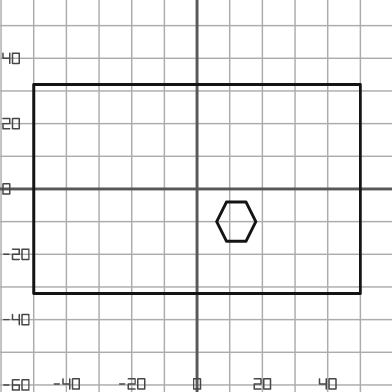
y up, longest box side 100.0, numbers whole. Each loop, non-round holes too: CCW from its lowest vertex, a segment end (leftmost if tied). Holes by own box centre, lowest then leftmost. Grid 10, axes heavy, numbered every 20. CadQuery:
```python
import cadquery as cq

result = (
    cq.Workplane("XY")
    .moveTo(-50.0, -32.0)
    .lineTo(50.0, -32.0)
    .lineTo(50.0, 32.0)
    .lineTo(-50.0, 32.0)
    .close()
    .moveTo(9.0, -16.0)
    .lineTo(15.0, -16.0)
    .lineTo(18.0, -10.0)
    .lineTo(15.0, -4.0)
    .lineTo(9.0, -4.0)
    .lineTo(6.0, -10.0)
    .close()
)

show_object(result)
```